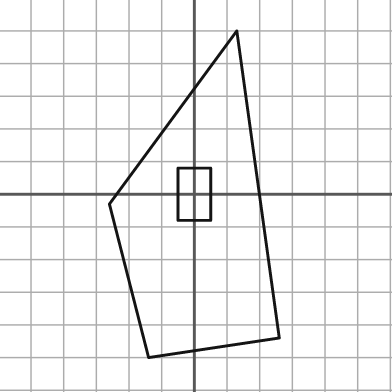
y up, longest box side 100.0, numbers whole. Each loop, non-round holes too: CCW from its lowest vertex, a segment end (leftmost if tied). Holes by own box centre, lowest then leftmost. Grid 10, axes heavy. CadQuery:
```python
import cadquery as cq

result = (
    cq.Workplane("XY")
    .moveTo(-14.0, -50.0)
    .lineTo(26.0, -44.0)
    .lineTo(13.0, 50.0)
    .lineTo(-26.0, -3.0)
    .close()
    .moveTo(-5.0, -8.0)
    .lineTo(5.0, -8.0)
    .lineTo(5.0, 8.0)
    .lineTo(-5.0, 8.0)
    .close()
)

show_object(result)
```